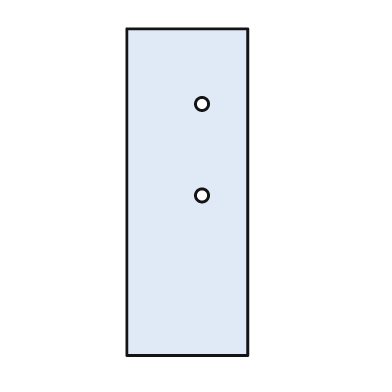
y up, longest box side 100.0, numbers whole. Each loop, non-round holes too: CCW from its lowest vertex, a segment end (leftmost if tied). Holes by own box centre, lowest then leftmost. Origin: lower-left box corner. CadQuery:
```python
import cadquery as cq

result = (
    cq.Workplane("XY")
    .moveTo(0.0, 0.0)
    .lineTo(37.0, 0.0)
    .lineTo(37.0, 100.0)
    .lineTo(0.0, 100.0)
    .close()
    .moveTo(23.0, 49.0)
    .circle(2.0)
    .moveTo(23.0, 77.0)
    .circle(2.0)
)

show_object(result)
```